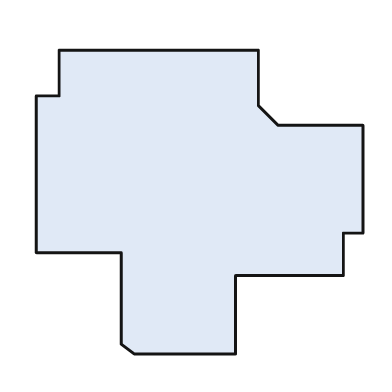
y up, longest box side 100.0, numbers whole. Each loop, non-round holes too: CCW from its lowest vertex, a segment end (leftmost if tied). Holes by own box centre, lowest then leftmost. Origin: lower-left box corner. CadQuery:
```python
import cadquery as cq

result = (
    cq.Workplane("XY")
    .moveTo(30.0, 0.0)
    .lineTo(61.0, 0.0)
    .lineTo(61.0, 24.0)
    .lineTo(94.0, 24.0)
    .lineTo(94.0, 37.0)
    .lineTo(100.0, 37.0)
    .lineTo(100.0, 70.0)
    .lineTo(74.0, 70.0)
    .lineTo(68.0, 76.0)
    .lineTo(68.0, 93.0)
    .lineTo(7.0, 93.0)
    .lineTo(7.0, 79.0)
    .lineTo(0.0, 79.0)
    .lineTo(0.0, 31.0)
    .lineTo(26.0, 31.0)
    .lineTo(26.0, 3.0)
    .close()
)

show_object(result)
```